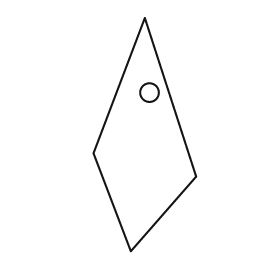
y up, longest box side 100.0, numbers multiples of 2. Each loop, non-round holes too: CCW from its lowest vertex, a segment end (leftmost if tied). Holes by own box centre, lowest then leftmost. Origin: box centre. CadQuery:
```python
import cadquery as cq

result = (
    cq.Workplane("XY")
    .moveTo(-6.0, -50.0)
    .lineTo(22.0, -18.0)
    .lineTo(0.0, 50.0)
    .lineTo(-22.0, -8.0)
    .close()
    .moveTo(2.0, 18.0)
    .circle(4.0)
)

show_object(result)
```